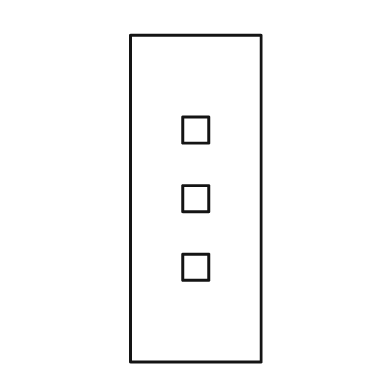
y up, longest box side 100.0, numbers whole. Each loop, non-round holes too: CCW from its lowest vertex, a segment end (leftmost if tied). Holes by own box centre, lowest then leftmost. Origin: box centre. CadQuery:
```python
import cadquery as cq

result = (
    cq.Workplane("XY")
    .moveTo(-20.0, -50.0)
    .lineTo(20.0, -50.0)
    .lineTo(20.0, 50.0)
    .lineTo(-20.0, 50.0)
    .close()
    .moveTo(-4.0, -25.0)
    .lineTo(4.0, -25.0)
    .lineTo(4.0, -17.0)
    .lineTo(-4.0, -17.0)
    .close()
    .moveTo(-4.0, -4.0)
    .lineTo(4.0, -4.0)
    .lineTo(4.0, 4.0)
    .lineTo(-4.0, 4.0)
    .close()
    .moveTo(-4.0, 17.0)
    .lineTo(4.0, 17.0)
    .lineTo(4.0, 25.0)
    .lineTo(-4.0, 25.0)
    .close()
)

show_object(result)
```